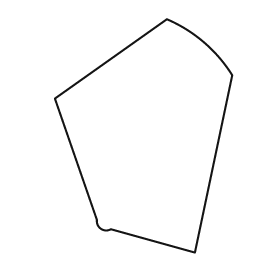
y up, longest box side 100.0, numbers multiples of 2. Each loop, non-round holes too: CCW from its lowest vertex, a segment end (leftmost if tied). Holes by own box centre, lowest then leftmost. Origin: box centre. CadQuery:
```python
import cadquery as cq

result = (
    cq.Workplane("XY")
    .moveTo(22.0, -50.0)
    .lineTo(38.0, 26.0)
    .threePointArc((26.0, 40.0), (10.0, 50.0))
    .lineTo(-38.0, 16.0)
    .lineTo(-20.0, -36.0)
    .threePointArc((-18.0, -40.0), (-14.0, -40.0))
    .close()
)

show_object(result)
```